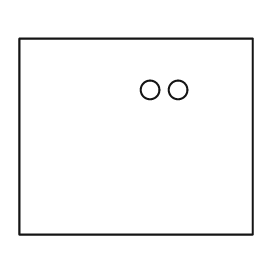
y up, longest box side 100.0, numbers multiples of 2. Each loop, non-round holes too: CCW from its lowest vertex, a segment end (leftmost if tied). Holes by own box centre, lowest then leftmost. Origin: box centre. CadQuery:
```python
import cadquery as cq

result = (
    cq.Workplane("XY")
    .moveTo(-50.0, -42.0)
    .lineTo(50.0, -42.0)
    .lineTo(50.0, 42.0)
    .lineTo(-50.0, 42.0)
    .close()
    .moveTo(6.0, 20.0)
    .circle(4.0)
    .moveTo(18.0, 20.0)
    .circle(4.0)
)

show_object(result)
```